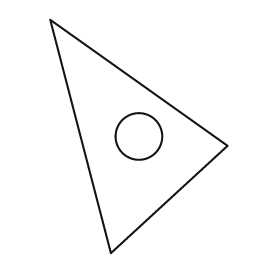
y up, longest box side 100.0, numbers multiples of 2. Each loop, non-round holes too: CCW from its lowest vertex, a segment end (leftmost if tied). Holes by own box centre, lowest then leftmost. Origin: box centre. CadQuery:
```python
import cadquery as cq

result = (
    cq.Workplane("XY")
    .moveTo(-12.0, -50.0)
    .lineTo(38.0, -4.0)
    .lineTo(-38.0, 50.0)
    .close()
    .moveTo(0.0, 0.0)
    .circle(10.0)
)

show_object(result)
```